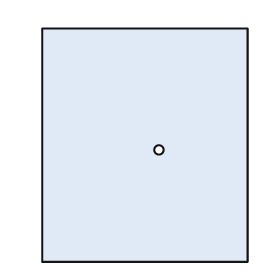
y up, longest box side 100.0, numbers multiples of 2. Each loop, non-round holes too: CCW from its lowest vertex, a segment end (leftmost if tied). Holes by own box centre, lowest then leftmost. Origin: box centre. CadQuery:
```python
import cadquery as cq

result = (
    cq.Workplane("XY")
    .moveTo(-44.0, -50.0)
    .lineTo(44.0, -50.0)
    .lineTo(44.0, 50.0)
    .lineTo(-44.0, 50.0)
    .close()
    .moveTo(6.0, -2.0)
    .circle(2.0)
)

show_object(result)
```